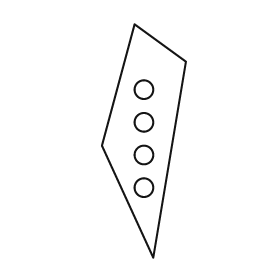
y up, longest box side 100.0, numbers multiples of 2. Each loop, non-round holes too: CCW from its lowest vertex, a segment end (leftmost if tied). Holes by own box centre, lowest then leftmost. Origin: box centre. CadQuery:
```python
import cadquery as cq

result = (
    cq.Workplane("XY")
    .moveTo(4.0, -50.0)
    .lineTo(18.0, 34.0)
    .lineTo(-4.0, 50.0)
    .lineTo(-18.0, -2.0)
    .close()
    .moveTo(0.0, -20.0)
    .circle(4.0)
    .moveTo(0.0, -6.0)
    .circle(4.0)
    .moveTo(0.0, 8.0)
    .circle(4.0)
    .moveTo(0.0, 22.0)
    .circle(4.0)
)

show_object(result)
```